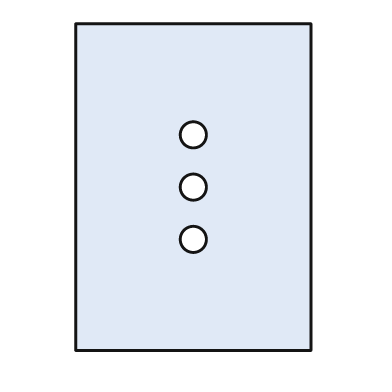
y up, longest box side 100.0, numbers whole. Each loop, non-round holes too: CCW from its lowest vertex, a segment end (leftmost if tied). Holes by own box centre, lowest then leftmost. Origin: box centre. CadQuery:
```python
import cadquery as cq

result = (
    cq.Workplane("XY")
    .moveTo(-36.0, -50.0)
    .lineTo(36.0, -50.0)
    .lineTo(36.0, 50.0)
    .lineTo(-36.0, 50.0)
    .close()
    .moveTo(0.0, -16.0)
    .circle(4.0)
    .moveTo(0.0, 0.0)
    .circle(4.0)
    .moveTo(0.0, 16.0)
    .circle(4.0)
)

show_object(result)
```